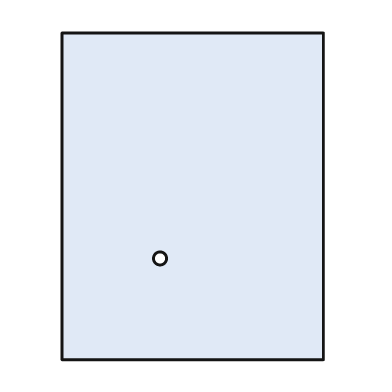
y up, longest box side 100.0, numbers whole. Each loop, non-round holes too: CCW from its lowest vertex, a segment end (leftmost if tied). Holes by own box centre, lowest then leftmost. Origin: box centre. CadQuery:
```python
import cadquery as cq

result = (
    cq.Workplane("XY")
    .moveTo(-40.0, -50.0)
    .lineTo(40.0, -50.0)
    .lineTo(40.0, 50.0)
    .lineTo(-40.0, 50.0)
    .close()
    .moveTo(-10.0, -19.0)
    .circle(2.0)
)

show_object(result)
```